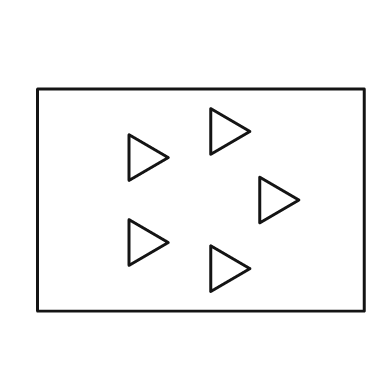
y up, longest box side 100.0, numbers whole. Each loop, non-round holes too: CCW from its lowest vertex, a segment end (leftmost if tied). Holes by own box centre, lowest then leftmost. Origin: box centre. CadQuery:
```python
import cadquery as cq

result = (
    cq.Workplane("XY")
    .moveTo(-50.0, -34.0)
    .lineTo(50.0, -34.0)
    .lineTo(50.0, 34.0)
    .lineTo(-50.0, 34.0)
    .close()
    .moveTo(3.0, -28.0)
    .lineTo(15.0, -21.0)
    .lineTo(3.0, -14.0)
    .close()
    .moveTo(-22.0, -20.0)
    .lineTo(-10.0, -13.0)
    .lineTo(-22.0, -6.0)
    .close()
    .moveTo(18.0, -7.0)
    .lineTo(30.0, 0.0)
    .lineTo(18.0, 7.0)
    .close()
    .moveTo(-22.0, 6.0)
    .lineTo(-10.0, 13.0)
    .lineTo(-22.0, 20.0)
    .close()
    .moveTo(3.0, 14.0)
    .lineTo(15.0, 21.0)
    .lineTo(3.0, 28.0)
    .close()
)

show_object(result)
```